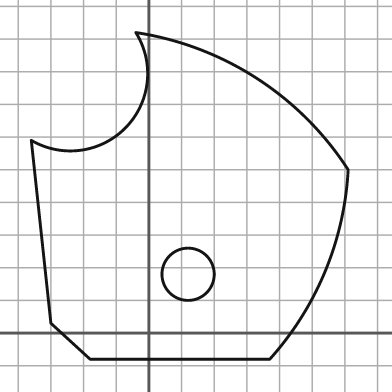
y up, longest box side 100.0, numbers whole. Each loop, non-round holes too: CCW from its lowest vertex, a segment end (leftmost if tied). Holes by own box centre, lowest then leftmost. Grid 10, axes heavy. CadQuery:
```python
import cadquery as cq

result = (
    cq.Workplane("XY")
    .moveTo(-18.0, -8.0)
    .lineTo(37.0, -8.0)
    .threePointArc((54.0, 19.0), (61.0, 50.0))
    .threePointArc((33.0, 78.0), (-4.0, 92.0))
    .threePointArc((-7.0, 63.0), (-36.0, 59.0))
    .lineTo(-30.0, 3.0)
    .close()
    .moveTo(12.0, 18.0)
    .circle(8.0)
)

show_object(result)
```